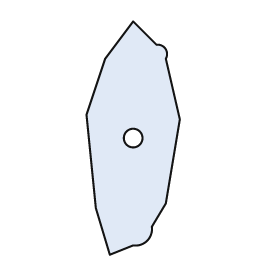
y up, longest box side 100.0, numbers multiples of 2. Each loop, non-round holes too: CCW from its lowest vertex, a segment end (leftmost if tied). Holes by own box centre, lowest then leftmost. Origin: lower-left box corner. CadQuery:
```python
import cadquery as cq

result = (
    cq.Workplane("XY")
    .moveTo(10.0, 0.0)
    .lineTo(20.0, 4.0)
    .threePointArc((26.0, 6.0), (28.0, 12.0))
    .lineTo(34.0, 22.0)
    .lineTo(40.0, 58.0)
    .lineTo(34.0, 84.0)
    .threePointArc((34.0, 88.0), (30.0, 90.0))
    .lineTo(20.0, 100.0)
    .lineTo(8.0, 84.0)
    .lineTo(0.0, 60.0)
    .lineTo(4.0, 20.0)
    .close()
    .moveTo(20.0, 50.0)
    .circle(4.0)
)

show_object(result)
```